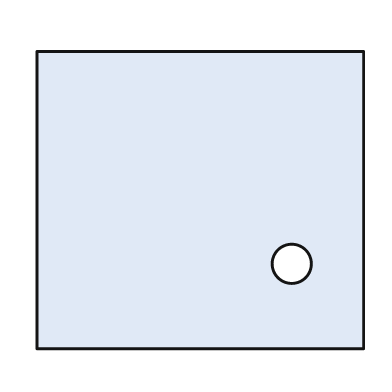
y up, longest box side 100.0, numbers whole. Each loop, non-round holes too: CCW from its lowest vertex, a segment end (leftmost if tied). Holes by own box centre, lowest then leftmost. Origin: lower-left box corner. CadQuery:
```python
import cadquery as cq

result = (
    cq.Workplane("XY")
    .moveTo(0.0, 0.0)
    .lineTo(100.0, 0.0)
    .lineTo(100.0, 91.0)
    .lineTo(0.0, 91.0)
    .close()
    .moveTo(78.0, 26.0)
    .circle(6.0)
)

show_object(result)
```